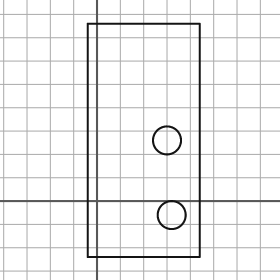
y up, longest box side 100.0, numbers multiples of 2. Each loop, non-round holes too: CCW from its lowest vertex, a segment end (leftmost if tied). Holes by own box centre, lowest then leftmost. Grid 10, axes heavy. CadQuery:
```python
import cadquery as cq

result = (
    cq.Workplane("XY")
    .moveTo(-4.0, -24.0)
    .lineTo(44.0, -24.0)
    .lineTo(44.0, 76.0)
    .lineTo(-4.0, 76.0)
    .close()
    .moveTo(32.0, -6.0)
    .circle(6.0)
    .moveTo(30.0, 26.0)
    .circle(6.0)
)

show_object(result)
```